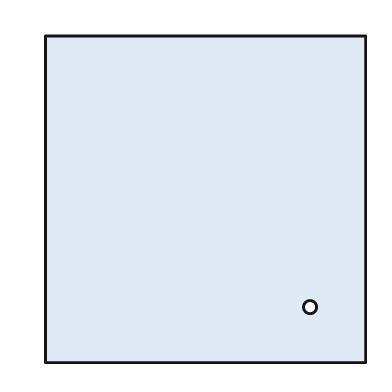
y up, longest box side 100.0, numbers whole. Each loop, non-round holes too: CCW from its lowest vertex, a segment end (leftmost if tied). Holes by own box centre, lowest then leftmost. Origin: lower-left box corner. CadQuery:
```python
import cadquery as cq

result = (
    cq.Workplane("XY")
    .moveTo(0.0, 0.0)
    .lineTo(98.0, 0.0)
    .lineTo(98.0, 100.0)
    .lineTo(0.0, 100.0)
    .close()
    .moveTo(81.0, 17.0)
    .circle(2.0)
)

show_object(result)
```